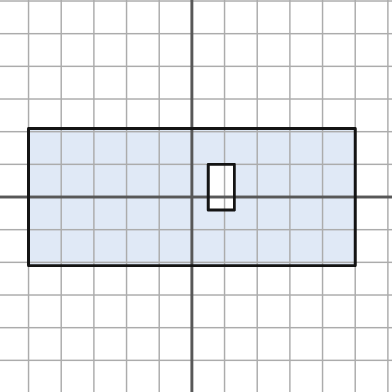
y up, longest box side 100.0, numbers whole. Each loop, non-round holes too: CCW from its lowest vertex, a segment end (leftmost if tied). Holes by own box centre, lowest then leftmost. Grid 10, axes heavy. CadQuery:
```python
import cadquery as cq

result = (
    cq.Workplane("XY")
    .moveTo(-50.0, -21.0)
    .lineTo(50.0, -21.0)
    .lineTo(50.0, 21.0)
    .lineTo(-50.0, 21.0)
    .close()
    .moveTo(5.0, -4.0)
    .lineTo(13.0, -4.0)
    .lineTo(13.0, 10.0)
    .lineTo(5.0, 10.0)
    .close()
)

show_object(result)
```